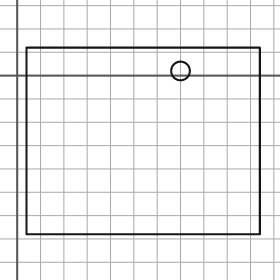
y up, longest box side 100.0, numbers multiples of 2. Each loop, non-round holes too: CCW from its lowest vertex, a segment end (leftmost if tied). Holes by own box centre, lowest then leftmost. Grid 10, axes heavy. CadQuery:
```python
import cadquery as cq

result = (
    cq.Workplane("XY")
    .moveTo(4.0, -68.0)
    .lineTo(104.0, -68.0)
    .lineTo(104.0, 12.0)
    .lineTo(4.0, 12.0)
    .close()
    .moveTo(70.0, 2.0)
    .circle(4.0)
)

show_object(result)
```